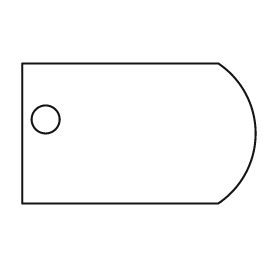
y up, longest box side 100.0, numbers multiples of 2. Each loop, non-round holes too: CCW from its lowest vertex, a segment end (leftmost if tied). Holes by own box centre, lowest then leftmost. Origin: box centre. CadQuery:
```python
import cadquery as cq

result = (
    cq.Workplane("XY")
    .moveTo(-50.0, -30.0)
    .lineTo(34.0, -30.0)
    .threePointArc((50.0, 0.0), (34.0, 30.0))
    .lineTo(-50.0, 30.0)
    .close()
    .moveTo(-40.0, 6.0)
    .circle(6.0)
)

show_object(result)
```